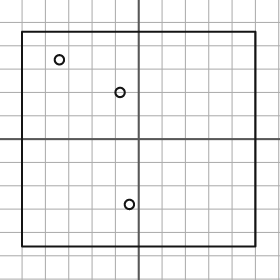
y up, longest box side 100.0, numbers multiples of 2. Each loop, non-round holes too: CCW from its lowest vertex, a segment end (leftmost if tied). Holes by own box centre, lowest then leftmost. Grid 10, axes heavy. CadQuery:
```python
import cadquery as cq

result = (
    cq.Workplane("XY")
    .moveTo(-50.0, -46.0)
    .lineTo(50.0, -46.0)
    .lineTo(50.0, 46.0)
    .lineTo(-50.0, 46.0)
    .close()
    .moveTo(-4.0, -28.0)
    .circle(2.0)
    .moveTo(-8.0, 20.0)
    .circle(2.0)
    .moveTo(-34.0, 34.0)
    .circle(2.0)
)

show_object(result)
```